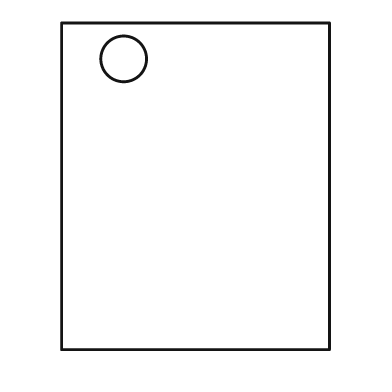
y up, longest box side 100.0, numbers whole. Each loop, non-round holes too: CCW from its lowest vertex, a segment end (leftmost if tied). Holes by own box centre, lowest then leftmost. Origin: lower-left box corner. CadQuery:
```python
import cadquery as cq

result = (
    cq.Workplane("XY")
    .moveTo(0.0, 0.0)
    .lineTo(82.0, 0.0)
    .lineTo(82.0, 100.0)
    .lineTo(0.0, 100.0)
    .close()
    .moveTo(19.0, 89.0)
    .circle(7.0)
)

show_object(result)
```